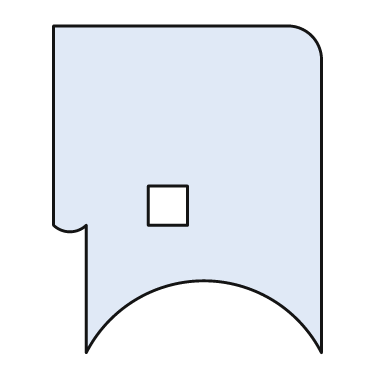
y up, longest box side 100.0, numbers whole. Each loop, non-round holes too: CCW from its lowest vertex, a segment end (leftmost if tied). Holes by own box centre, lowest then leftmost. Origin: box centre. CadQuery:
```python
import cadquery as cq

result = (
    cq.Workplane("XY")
    .moveTo(-31.0, -50.0)
    .threePointArc((5.0, -28.0), (41.0, -50.0))
    .lineTo(41.0, 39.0)
    .threePointArc((38.0, 47.0), (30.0, 50.0))
    .lineTo(-41.0, 50.0)
    .lineTo(-41.0, -11.0)
    .threePointArc((-36.0, -13.0), (-31.0, -11.0))
    .close()
    .moveTo(-12.0, -11.0)
    .lineTo(0.0, -11.0)
    .lineTo(0.0, 1.0)
    .lineTo(-12.0, 1.0)
    .close()
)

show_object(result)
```